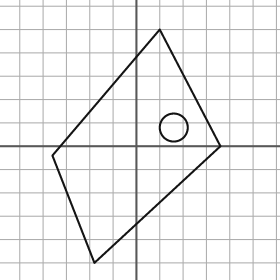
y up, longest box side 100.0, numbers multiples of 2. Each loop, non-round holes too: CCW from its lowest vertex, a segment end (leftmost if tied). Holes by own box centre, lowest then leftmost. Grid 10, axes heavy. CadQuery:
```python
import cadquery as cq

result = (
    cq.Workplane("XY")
    .moveTo(-18.0, -50.0)
    .lineTo(36.0, 0.0)
    .lineTo(10.0, 50.0)
    .lineTo(-36.0, -4.0)
    .close()
    .moveTo(16.0, 8.0)
    .circle(6.0)
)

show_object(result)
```